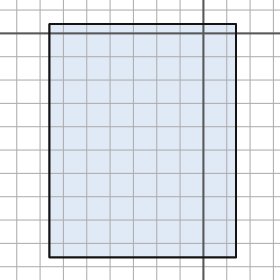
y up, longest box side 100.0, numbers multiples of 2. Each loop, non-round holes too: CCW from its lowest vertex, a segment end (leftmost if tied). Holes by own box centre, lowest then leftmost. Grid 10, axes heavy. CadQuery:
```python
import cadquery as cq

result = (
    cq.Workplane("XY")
    .moveTo(-66.0, -96.0)
    .lineTo(14.0, -96.0)
    .lineTo(14.0, 4.0)
    .lineTo(-66.0, 4.0)
    .close()
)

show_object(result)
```